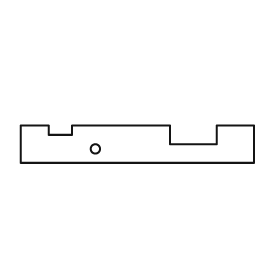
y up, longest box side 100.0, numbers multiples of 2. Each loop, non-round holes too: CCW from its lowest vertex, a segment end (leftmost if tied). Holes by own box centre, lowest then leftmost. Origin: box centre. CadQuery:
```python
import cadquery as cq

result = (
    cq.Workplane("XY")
    .moveTo(-50.0, -8.0)
    .lineTo(50.0, -8.0)
    .lineTo(50.0, 8.0)
    .lineTo(34.0, 8.0)
    .lineTo(34.0, 0.0)
    .lineTo(14.0, 0.0)
    .lineTo(14.0, 8.0)
    .lineTo(-28.0, 8.0)
    .lineTo(-28.0, 4.0)
    .lineTo(-38.0, 4.0)
    .lineTo(-38.0, 8.0)
    .lineTo(-50.0, 8.0)
    .close()
    .moveTo(-18.0, -2.0)
    .circle(2.0)
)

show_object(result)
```